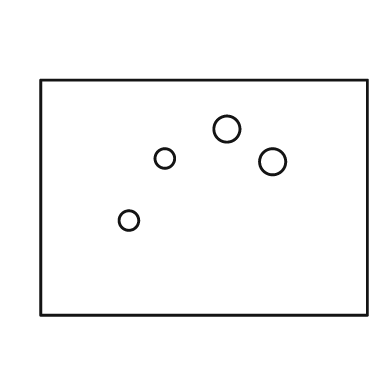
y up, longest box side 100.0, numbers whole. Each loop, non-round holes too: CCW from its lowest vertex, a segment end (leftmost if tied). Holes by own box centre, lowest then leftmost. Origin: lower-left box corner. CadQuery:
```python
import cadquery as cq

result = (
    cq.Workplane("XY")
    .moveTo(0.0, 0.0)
    .lineTo(100.0, 0.0)
    .lineTo(100.0, 72.0)
    .lineTo(0.0, 72.0)
    .close()
    .moveTo(27.0, 29.0)
    .circle(3.0)
    .moveTo(71.0, 47.0)
    .circle(4.0)
    .moveTo(38.0, 48.0)
    .circle(3.0)
    .moveTo(57.0, 57.0)
    .circle(4.0)
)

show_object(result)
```